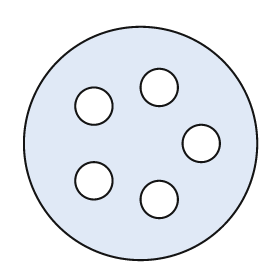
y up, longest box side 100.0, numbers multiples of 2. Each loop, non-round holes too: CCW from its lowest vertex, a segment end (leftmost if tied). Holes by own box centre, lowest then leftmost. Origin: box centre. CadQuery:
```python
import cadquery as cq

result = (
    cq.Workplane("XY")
    .moveTo(0.0, 0.0)
    .circle(50.0)
    .moveTo(8.0, -24.0)
    .circle(8.0)
    .moveTo(-20.0, -16.0)
    .circle(8.0)
    .moveTo(26.0, 0.0)
    .circle(8.0)
    .moveTo(-20.0, 16.0)
    .circle(8.0)
    .moveTo(8.0, 24.0)
    .circle(8.0)
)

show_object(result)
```